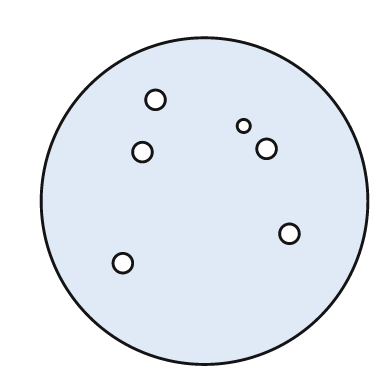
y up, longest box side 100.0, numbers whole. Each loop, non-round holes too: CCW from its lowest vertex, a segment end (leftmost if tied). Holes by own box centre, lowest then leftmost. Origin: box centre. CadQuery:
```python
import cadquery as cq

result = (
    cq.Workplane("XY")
    .moveTo(0.0, 0.0)
    .circle(50.0)
    .moveTo(-25.0, -19.0)
    .circle(3.0)
    .moveTo(26.0, -10.0)
    .circle(3.0)
    .moveTo(-19.0, 15.0)
    .circle(3.0)
    .moveTo(19.0, 16.0)
    .circle(3.0)
    .moveTo(12.0, 23.0)
    .circle(2.0)
    .moveTo(-15.0, 31.0)
    .circle(3.0)
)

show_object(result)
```